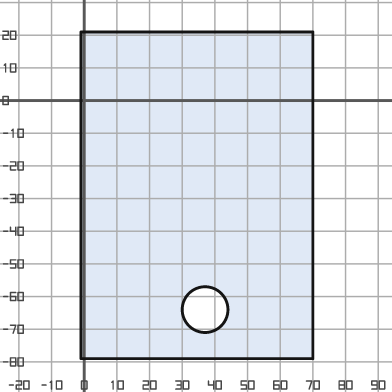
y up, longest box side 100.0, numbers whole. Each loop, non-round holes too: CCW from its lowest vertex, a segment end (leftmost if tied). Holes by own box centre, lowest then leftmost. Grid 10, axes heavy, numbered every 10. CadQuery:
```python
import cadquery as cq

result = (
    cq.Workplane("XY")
    .moveTo(-1.0, -79.0)
    .lineTo(70.0, -79.0)
    .lineTo(70.0, 21.0)
    .lineTo(-1.0, 21.0)
    .close()
    .moveTo(37.0, -64.0)
    .circle(7.0)
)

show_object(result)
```